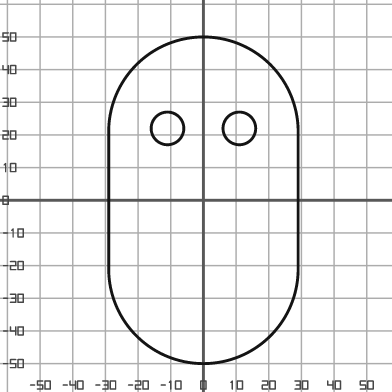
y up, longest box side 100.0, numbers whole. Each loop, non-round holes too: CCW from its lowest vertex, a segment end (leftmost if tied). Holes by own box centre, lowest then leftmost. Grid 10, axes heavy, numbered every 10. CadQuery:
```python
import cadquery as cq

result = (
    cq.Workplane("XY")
    .moveTo(-29.0, -21.0)
    .threePointArc((0.0, -50.0), (29.0, -21.0))
    .lineTo(29.0, 21.0)
    .threePointArc((0.0, 50.0), (-29.0, 21.0))
    .close()
    .moveTo(-11.0, 22.0)
    .circle(5.0)
    .moveTo(11.0, 22.0)
    .circle(5.0)
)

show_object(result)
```